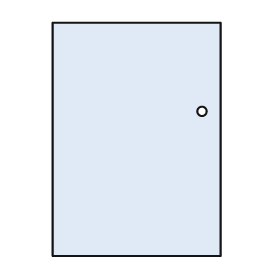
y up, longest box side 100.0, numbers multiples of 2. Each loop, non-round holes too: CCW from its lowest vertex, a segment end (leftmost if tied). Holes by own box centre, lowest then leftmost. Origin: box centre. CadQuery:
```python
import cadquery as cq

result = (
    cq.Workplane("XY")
    .moveTo(-36.0, -50.0)
    .lineTo(36.0, -50.0)
    .lineTo(36.0, 50.0)
    .lineTo(-36.0, 50.0)
    .close()
    .moveTo(28.0, 12.0)
    .circle(2.0)
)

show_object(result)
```